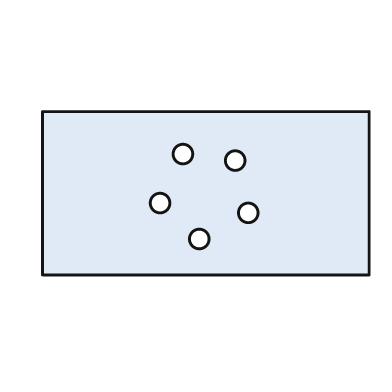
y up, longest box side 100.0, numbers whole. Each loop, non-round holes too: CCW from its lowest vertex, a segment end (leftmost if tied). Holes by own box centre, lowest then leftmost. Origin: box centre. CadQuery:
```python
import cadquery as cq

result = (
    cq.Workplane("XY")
    .moveTo(-50.0, -25.0)
    .lineTo(50.0, -25.0)
    .lineTo(50.0, 25.0)
    .lineTo(-50.0, 25.0)
    .close()
    .moveTo(-2.0, -14.0)
    .circle(3.0)
    .moveTo(13.0, -6.0)
    .circle(3.0)
    .moveTo(-14.0, -3.0)
    .circle(3.0)
    .moveTo(9.0, 10.0)
    .circle(3.0)
    .moveTo(-7.0, 12.0)
    .circle(3.0)
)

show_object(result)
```